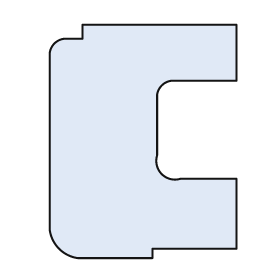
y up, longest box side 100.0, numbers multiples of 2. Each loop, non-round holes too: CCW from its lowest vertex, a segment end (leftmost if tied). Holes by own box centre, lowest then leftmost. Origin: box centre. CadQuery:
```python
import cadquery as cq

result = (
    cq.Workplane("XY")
    .moveTo(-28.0, -50.0)
    .lineTo(4.0, -50.0)
    .lineTo(4.0, -46.0)
    .lineTo(40.0, -46.0)
    .lineTo(40.0, -16.0)
    .lineTo(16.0, -16.0)
    .threePointArc((8.0, -14.0), (6.0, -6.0))
    .lineTo(6.0, 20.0)
    .threePointArc((8.0, 24.0), (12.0, 26.0))
    .lineTo(40.0, 26.0)
    .lineTo(40.0, 50.0)
    .lineTo(-26.0, 50.0)
    .lineTo(-26.0, 44.0)
    .lineTo(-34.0, 44.0)
    .threePointArc((-38.0, 42.0), (-40.0, 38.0))
    .lineTo(-40.0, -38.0)
    .threePointArc((-36.0, -46.0), (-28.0, -50.0))
    .close()
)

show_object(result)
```